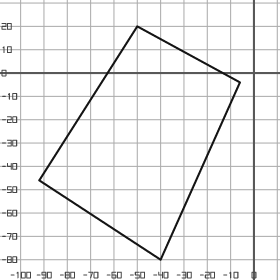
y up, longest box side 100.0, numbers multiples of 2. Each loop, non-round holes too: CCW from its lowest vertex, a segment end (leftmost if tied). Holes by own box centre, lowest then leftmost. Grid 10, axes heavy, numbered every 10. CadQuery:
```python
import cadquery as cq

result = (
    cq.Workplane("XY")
    .moveTo(-40.0, -80.0)
    .lineTo(-6.0, -4.0)
    .lineTo(-50.0, 20.0)
    .lineTo(-92.0, -46.0)
    .close()
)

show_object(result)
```